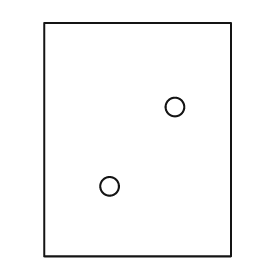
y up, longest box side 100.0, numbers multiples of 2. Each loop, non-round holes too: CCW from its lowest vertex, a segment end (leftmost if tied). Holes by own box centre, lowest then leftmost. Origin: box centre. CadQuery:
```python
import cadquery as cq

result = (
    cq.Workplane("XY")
    .moveTo(-40.0, -50.0)
    .lineTo(40.0, -50.0)
    .lineTo(40.0, 50.0)
    .lineTo(-40.0, 50.0)
    .close()
    .moveTo(-12.0, -20.0)
    .circle(4.0)
    .moveTo(16.0, 14.0)
    .circle(4.0)
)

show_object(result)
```